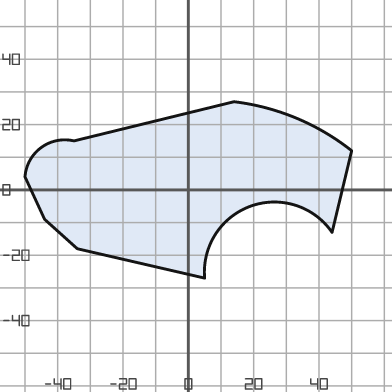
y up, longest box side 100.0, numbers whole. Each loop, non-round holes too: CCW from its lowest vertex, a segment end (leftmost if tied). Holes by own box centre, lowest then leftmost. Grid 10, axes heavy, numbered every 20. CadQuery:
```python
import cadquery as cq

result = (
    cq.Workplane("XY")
    .moveTo(5.0, -27.0)
    .threePointArc((19.0, -5.0), (44.0, -13.0))
    .lineTo(50.0, 12.0)
    .threePointArc((33.0, 22.0), (14.0, 27.0))
    .lineTo(-35.0, 15.0)
    .threePointArc((-45.0, 13.0), (-50.0, 4.0))
    .lineTo(-44.0, -9.0)
    .lineTo(-34.0, -18.0)
    .close()
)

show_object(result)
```